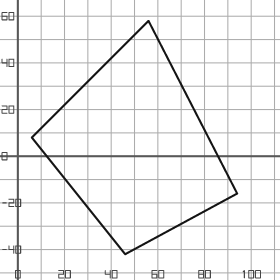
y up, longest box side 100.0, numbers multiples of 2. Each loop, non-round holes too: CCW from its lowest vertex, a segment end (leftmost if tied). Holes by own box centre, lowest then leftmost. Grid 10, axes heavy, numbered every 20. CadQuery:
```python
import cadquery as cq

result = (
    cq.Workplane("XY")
    .moveTo(46.0, -42.0)
    .lineTo(94.0, -16.0)
    .lineTo(56.0, 58.0)
    .lineTo(6.0, 8.0)
    .close()
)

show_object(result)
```